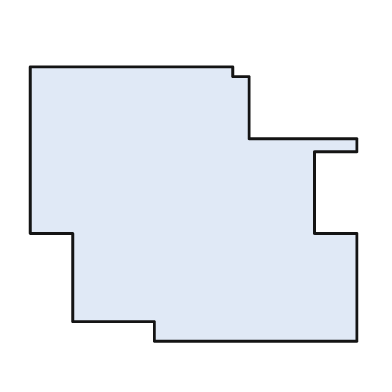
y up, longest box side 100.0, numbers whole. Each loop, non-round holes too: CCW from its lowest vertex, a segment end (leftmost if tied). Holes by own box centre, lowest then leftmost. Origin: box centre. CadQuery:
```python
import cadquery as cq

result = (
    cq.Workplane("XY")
    .moveTo(-12.0, -42.0)
    .lineTo(50.0, -42.0)
    .lineTo(50.0, -9.0)
    .lineTo(37.0, -9.0)
    .lineTo(37.0, 16.0)
    .lineTo(50.0, 16.0)
    .lineTo(50.0, 20.0)
    .lineTo(17.0, 20.0)
    .lineTo(17.0, 39.0)
    .lineTo(12.0, 39.0)
    .lineTo(12.0, 42.0)
    .lineTo(-50.0, 42.0)
    .lineTo(-50.0, -9.0)
    .lineTo(-37.0, -9.0)
    .lineTo(-37.0, -36.0)
    .lineTo(-12.0, -36.0)
    .close()
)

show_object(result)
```